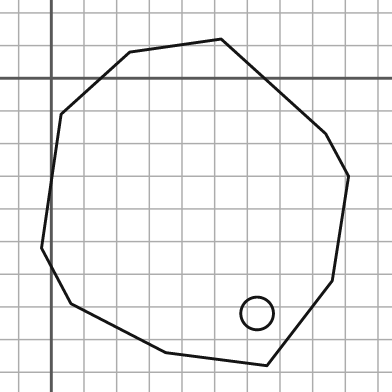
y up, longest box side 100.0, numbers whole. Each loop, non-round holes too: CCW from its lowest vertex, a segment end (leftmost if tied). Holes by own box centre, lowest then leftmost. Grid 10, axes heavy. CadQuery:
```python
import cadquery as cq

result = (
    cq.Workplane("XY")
    .moveTo(66.0, -88.0)
    .lineTo(86.0, -62.0)
    .lineTo(91.0, -30.0)
    .lineTo(84.0, -17.0)
    .lineTo(52.0, 12.0)
    .lineTo(24.0, 8.0)
    .lineTo(3.0, -11.0)
    .lineTo(-3.0, -52.0)
    .lineTo(6.0, -69.0)
    .lineTo(35.0, -84.0)
    .close()
    .moveTo(63.0, -72.0)
    .circle(5.0)
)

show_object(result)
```